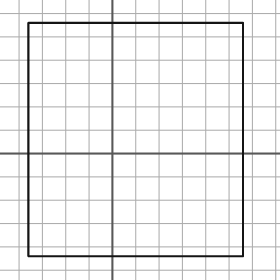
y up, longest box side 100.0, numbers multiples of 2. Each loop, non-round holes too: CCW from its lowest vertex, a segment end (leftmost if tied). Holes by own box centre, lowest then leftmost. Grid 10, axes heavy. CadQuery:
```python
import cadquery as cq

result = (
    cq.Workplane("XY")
    .moveTo(-36.0, -44.0)
    .lineTo(56.0, -44.0)
    .lineTo(56.0, 56.0)
    .lineTo(-36.0, 56.0)
    .close()
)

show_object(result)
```